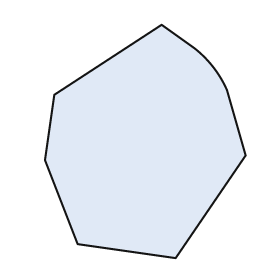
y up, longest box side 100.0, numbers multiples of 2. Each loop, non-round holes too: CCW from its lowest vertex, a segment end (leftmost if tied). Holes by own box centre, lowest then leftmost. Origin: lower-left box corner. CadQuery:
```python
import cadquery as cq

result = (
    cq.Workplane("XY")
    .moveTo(56.0, 0.0)
    .lineTo(86.0, 44.0)
    .lineTo(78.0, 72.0)
    .threePointArc((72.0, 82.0), (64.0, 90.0))
    .lineTo(50.0, 100.0)
    .lineTo(4.0, 70.0)
    .lineTo(0.0, 42.0)
    .lineTo(14.0, 6.0)
    .close()
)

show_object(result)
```